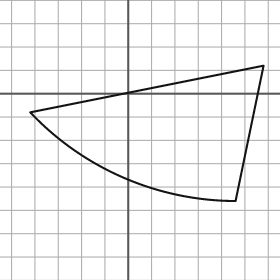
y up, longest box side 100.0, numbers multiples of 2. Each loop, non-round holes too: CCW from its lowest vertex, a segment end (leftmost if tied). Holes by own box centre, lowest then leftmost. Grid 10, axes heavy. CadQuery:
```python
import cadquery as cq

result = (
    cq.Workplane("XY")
    .moveTo(46.0, -46.0)
    .lineTo(58.0, 12.0)
    .lineTo(-42.0, -8.0)
    .threePointArc((-2.0, -36.0), (46.0, -46.0))
    .close()
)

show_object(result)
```